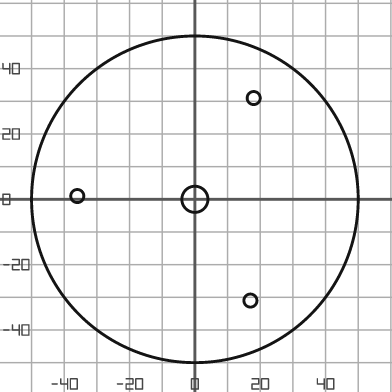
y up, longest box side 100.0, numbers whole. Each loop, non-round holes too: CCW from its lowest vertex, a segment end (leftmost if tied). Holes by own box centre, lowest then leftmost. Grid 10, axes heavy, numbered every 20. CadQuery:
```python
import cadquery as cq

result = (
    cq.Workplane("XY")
    .moveTo(0.0, 0.0)
    .circle(50.0)
    .moveTo(17.0, -31.0)
    .circle(2.0)
    .moveTo(0.0, 0.0)
    .circle(4.0)
    .moveTo(-36.0, 1.0)
    .circle(2.0)
    .moveTo(18.0, 31.0)
    .circle(2.0)
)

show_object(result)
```